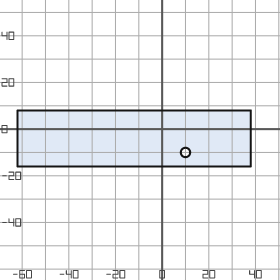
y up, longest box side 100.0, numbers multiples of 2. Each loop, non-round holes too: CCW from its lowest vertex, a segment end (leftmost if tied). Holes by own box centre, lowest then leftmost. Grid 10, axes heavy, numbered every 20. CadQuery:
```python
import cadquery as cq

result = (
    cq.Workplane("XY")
    .moveTo(-62.0, -16.0)
    .lineTo(38.0, -16.0)
    .lineTo(38.0, 8.0)
    .lineTo(-62.0, 8.0)
    .close()
    .moveTo(10.0, -10.0)
    .circle(2.0)
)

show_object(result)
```